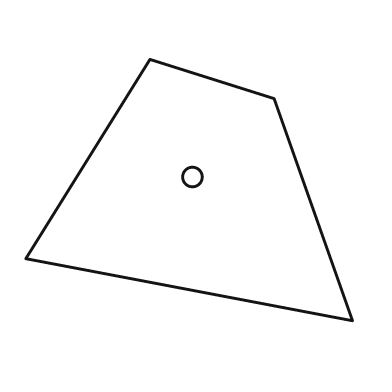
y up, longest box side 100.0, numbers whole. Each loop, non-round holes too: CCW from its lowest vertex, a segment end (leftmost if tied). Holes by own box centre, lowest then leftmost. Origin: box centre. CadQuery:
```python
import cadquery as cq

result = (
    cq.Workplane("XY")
    .moveTo(50.0, -40.0)
    .lineTo(26.0, 28.0)
    .lineTo(-12.0, 40.0)
    .lineTo(-50.0, -21.0)
    .close()
    .moveTo(1.0, 4.0)
    .circle(3.0)
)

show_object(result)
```